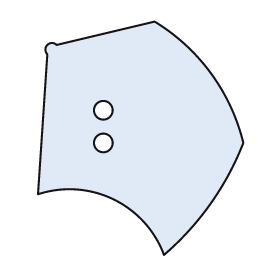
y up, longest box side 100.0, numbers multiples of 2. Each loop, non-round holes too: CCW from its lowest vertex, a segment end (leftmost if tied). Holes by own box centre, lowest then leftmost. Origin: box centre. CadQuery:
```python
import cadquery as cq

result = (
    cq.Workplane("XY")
    .moveTo(10.0, -50.0)
    .threePointArc((30.0, -28.0), (44.0, -2.0))
    .threePointArc((30.0, 28.0), (6.0, 50.0))
    .lineTo(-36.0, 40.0)
    .threePointArc((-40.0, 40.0), (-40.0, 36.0))
    .lineTo(-44.0, -24.0)
    .threePointArc((-12.0, -26.0), (10.0, -50.0))
    .close()
    .moveTo(-16.0, -2.0)
    .circle(4.0)
    .moveTo(-16.0, 12.0)
    .circle(4.0)
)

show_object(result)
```